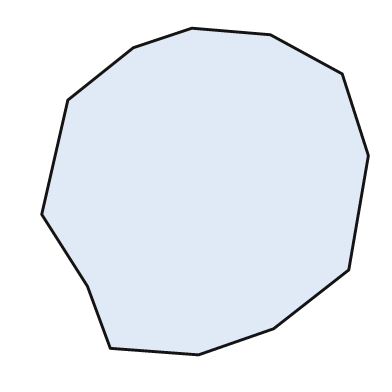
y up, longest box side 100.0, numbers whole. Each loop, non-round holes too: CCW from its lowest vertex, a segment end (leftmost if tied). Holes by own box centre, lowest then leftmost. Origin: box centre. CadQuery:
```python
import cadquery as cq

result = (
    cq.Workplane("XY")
    .moveTo(-2.0, -50.0)
    .lineTo(21.0, -42.0)
    .lineTo(44.0, -24.0)
    .lineTo(50.0, 11.0)
    .lineTo(42.0, 36.0)
    .lineTo(20.0, 48.0)
    .lineTo(-4.0, 50.0)
    .lineTo(-22.0, 44.0)
    .lineTo(-42.0, 28.0)
    .lineTo(-50.0, -7.0)
    .lineTo(-36.0, -29.0)
    .lineTo(-29.0, -48.0)
    .close()
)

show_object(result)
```